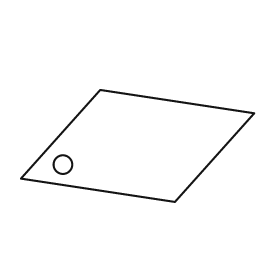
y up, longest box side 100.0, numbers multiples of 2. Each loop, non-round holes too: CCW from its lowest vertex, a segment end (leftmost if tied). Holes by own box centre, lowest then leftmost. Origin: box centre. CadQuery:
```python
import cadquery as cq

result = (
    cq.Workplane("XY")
    .moveTo(16.0, -24.0)
    .lineTo(50.0, 14.0)
    .lineTo(-16.0, 24.0)
    .lineTo(-50.0, -14.0)
    .close()
    .moveTo(-32.0, -8.0)
    .circle(4.0)
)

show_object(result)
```